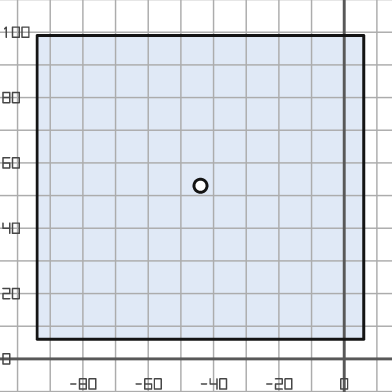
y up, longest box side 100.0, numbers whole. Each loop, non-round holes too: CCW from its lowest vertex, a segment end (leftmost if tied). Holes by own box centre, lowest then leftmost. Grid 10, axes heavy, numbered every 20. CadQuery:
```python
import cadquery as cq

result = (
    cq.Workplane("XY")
    .moveTo(-94.0, 6.0)
    .lineTo(6.0, 6.0)
    .lineTo(6.0, 99.0)
    .lineTo(-94.0, 99.0)
    .close()
    .moveTo(-44.0, 53.0)
    .circle(2.0)
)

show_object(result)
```